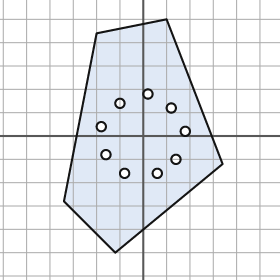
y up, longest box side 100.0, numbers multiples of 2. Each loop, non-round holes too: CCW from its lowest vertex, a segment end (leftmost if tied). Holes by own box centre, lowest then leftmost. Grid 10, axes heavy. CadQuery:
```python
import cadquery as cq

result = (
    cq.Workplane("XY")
    .moveTo(-12.0, -50.0)
    .lineTo(34.0, -12.0)
    .lineTo(10.0, 50.0)
    .lineTo(-20.0, 44.0)
    .lineTo(-34.0, -28.0)
    .close()
    .moveTo(-8.0, -16.0)
    .circle(2.0)
    .moveTo(6.0, -16.0)
    .circle(2.0)
    .moveTo(14.0, -10.0)
    .circle(2.0)
    .moveTo(-16.0, -8.0)
    .circle(2.0)
    .moveTo(18.0, 2.0)
    .circle(2.0)
    .moveTo(-18.0, 4.0)
    .circle(2.0)
    .moveTo(12.0, 12.0)
    .circle(2.0)
    .moveTo(-10.0, 14.0)
    .circle(2.0)
    .moveTo(2.0, 18.0)
    .circle(2.0)
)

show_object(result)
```